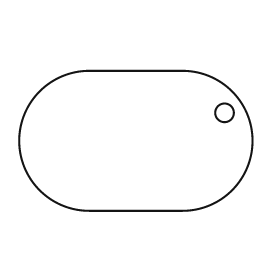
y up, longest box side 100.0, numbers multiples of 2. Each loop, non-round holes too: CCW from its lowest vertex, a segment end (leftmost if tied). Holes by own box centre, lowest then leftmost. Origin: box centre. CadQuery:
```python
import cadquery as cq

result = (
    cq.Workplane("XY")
    .moveTo(-20.0, -30.0)
    .lineTo(20.0, -30.0)
    .threePointArc((50.0, 0.0), (20.0, 30.0))
    .lineTo(-20.0, 30.0)
    .threePointArc((-50.0, 0.0), (-20.0, -30.0))
    .close()
    .moveTo(38.0, 12.0)
    .circle(4.0)
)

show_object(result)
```